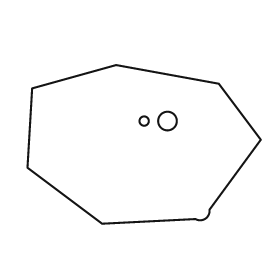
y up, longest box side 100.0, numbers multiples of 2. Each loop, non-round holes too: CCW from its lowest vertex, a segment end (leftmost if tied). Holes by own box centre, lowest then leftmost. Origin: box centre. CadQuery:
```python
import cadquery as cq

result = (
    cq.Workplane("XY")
    .moveTo(-18.0, -34.0)
    .lineTo(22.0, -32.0)
    .threePointArc((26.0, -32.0), (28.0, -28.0))
    .lineTo(50.0, 2.0)
    .lineTo(32.0, 26.0)
    .lineTo(-12.0, 34.0)
    .lineTo(-48.0, 24.0)
    .lineTo(-50.0, -10.0)
    .close()
    .moveTo(0.0, 10.0)
    .circle(2.0)
    .moveTo(10.0, 10.0)
    .circle(4.0)
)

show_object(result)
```